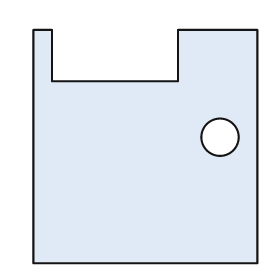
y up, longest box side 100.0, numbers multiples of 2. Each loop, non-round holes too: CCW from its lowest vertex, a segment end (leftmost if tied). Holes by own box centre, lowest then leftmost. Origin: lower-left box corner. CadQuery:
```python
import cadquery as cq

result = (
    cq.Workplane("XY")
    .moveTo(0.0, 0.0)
    .lineTo(96.0, 0.0)
    .lineTo(96.0, 100.0)
    .lineTo(62.0, 100.0)
    .lineTo(62.0, 78.0)
    .lineTo(8.0, 78.0)
    .lineTo(8.0, 100.0)
    .lineTo(0.0, 100.0)
    .close()
    .moveTo(80.0, 54.0)
    .circle(8.0)
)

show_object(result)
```